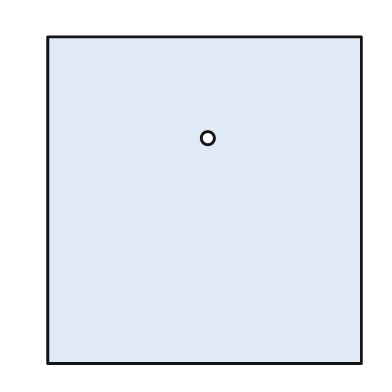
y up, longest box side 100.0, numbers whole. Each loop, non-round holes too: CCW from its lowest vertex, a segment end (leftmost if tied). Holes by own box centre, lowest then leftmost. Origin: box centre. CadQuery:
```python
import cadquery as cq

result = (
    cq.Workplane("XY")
    .moveTo(-48.0, -50.0)
    .lineTo(48.0, -50.0)
    .lineTo(48.0, 50.0)
    .lineTo(-48.0, 50.0)
    .close()
    .moveTo(1.0, 19.0)
    .circle(2.0)
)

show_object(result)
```